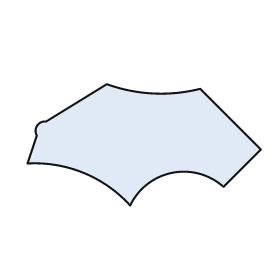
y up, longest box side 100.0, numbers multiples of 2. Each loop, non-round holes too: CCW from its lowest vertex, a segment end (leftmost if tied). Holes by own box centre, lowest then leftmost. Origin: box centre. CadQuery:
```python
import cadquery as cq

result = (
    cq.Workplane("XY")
    .moveTo(-6.0, -26.0)
    .threePointArc((12.0, -12.0), (34.0, -18.0))
    .lineTo(50.0, -2.0)
    .lineTo(24.0, 24.0)
    .threePointArc((4.0, 22.0), (-16.0, 26.0))
    .lineTo(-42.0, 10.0)
    .threePointArc((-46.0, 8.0), (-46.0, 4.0))
    .lineTo(-50.0, -8.0)
    .threePointArc((-26.0, -12.0), (-6.0, -26.0))
    .close()
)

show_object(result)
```